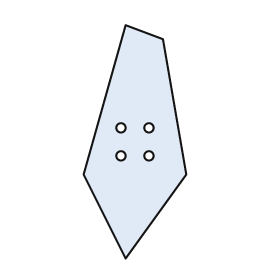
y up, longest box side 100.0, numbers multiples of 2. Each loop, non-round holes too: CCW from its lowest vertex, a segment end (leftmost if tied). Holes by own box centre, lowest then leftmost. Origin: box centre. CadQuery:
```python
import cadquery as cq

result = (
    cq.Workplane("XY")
    .moveTo(-4.0, -50.0)
    .lineTo(22.0, -14.0)
    .lineTo(12.0, 44.0)
    .lineTo(-4.0, 50.0)
    .lineTo(-22.0, -14.0)
    .close()
    .moveTo(-6.0, -6.0)
    .circle(2.0)
    .moveTo(6.0, -6.0)
    .circle(2.0)
    .moveTo(-6.0, 6.0)
    .circle(2.0)
    .moveTo(6.0, 6.0)
    .circle(2.0)
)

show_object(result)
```